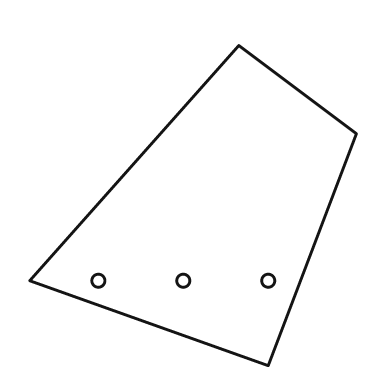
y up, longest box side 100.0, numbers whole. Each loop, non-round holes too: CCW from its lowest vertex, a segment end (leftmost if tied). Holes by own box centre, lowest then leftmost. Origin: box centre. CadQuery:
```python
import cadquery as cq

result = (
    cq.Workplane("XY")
    .moveTo(23.0, -49.0)
    .lineTo(50.0, 22.0)
    .lineTo(14.0, 49.0)
    .lineTo(-50.0, -23.0)
    .close()
    .moveTo(-29.0, -23.0)
    .circle(2.0)
    .moveTo(-3.0, -23.0)
    .circle(2.0)
    .moveTo(23.0, -23.0)
    .circle(2.0)
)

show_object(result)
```